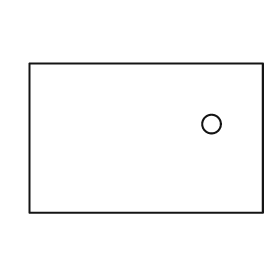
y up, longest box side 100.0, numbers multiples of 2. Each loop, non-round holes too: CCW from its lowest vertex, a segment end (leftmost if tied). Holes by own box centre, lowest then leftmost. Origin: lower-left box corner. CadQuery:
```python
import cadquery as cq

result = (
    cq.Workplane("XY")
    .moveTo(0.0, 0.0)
    .lineTo(100.0, 0.0)
    .lineTo(100.0, 64.0)
    .lineTo(0.0, 64.0)
    .close()
    .moveTo(78.0, 38.0)
    .circle(4.0)
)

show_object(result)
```